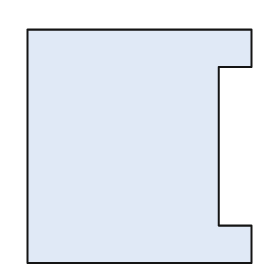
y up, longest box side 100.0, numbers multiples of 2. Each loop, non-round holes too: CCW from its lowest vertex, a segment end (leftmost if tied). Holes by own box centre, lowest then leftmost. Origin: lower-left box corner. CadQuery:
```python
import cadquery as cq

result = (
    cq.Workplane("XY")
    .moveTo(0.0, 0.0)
    .lineTo(96.0, 0.0)
    .lineTo(96.0, 16.0)
    .lineTo(82.0, 16.0)
    .lineTo(82.0, 84.0)
    .lineTo(96.0, 84.0)
    .lineTo(96.0, 100.0)
    .lineTo(0.0, 100.0)
    .close()
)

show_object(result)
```